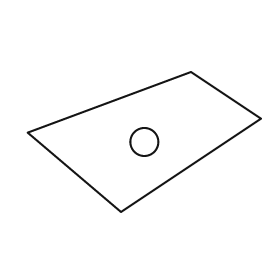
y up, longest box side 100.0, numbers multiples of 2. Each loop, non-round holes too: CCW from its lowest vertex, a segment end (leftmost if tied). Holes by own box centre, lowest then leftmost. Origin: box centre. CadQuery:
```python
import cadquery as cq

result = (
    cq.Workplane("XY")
    .moveTo(-10.0, -30.0)
    .lineTo(50.0, 10.0)
    .lineTo(20.0, 30.0)
    .lineTo(-50.0, 4.0)
    .close()
    .moveTo(0.0, 0.0)
    .circle(6.0)
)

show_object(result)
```